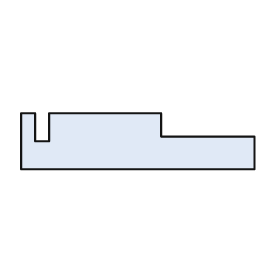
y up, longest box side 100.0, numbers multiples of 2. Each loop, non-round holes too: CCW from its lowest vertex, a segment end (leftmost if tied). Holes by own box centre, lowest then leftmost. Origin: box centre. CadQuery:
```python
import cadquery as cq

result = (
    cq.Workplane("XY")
    .moveTo(-50.0, -12.0)
    .lineTo(50.0, -12.0)
    .lineTo(50.0, 2.0)
    .lineTo(10.0, 2.0)
    .lineTo(10.0, 12.0)
    .lineTo(-38.0, 12.0)
    .lineTo(-38.0, 0.0)
    .lineTo(-44.0, 0.0)
    .lineTo(-44.0, 12.0)
    .lineTo(-50.0, 12.0)
    .close()
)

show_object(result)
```